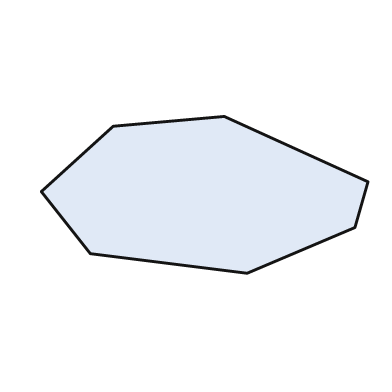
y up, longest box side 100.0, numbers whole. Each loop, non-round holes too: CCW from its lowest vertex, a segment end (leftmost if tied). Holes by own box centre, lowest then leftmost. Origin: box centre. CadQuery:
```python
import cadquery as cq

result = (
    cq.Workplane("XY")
    .moveTo(13.0, -24.0)
    .lineTo(46.0, -10.0)
    .lineTo(50.0, 4.0)
    .lineTo(6.0, 24.0)
    .lineTo(-28.0, 21.0)
    .lineTo(-50.0, 1.0)
    .lineTo(-35.0, -18.0)
    .close()
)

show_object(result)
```